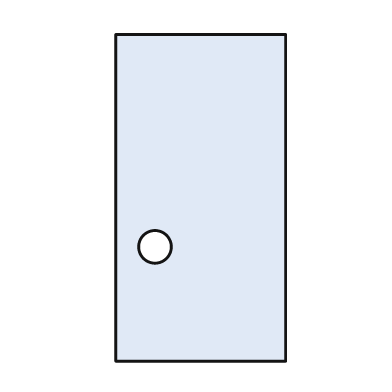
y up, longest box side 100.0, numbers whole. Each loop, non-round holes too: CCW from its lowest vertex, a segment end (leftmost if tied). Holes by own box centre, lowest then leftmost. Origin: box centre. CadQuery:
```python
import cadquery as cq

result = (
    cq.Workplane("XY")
    .moveTo(-26.0, -50.0)
    .lineTo(26.0, -50.0)
    .lineTo(26.0, 50.0)
    .lineTo(-26.0, 50.0)
    .close()
    .moveTo(-14.0, -15.0)
    .circle(5.0)
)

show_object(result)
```